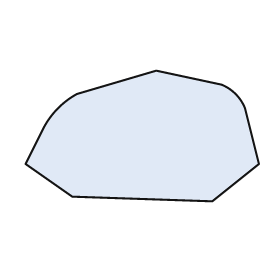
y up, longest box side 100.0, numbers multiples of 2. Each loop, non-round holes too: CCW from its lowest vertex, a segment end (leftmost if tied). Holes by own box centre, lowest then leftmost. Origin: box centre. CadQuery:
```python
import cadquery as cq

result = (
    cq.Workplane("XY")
    .moveTo(30.0, -28.0)
    .lineTo(50.0, -12.0)
    .lineTo(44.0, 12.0)
    .threePointArc((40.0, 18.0), (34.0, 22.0))
    .lineTo(6.0, 28.0)
    .lineTo(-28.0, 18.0)
    .threePointArc((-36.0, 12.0), (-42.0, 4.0))
    .lineTo(-50.0, -12.0)
    .lineTo(-30.0, -26.0)
    .close()
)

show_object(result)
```